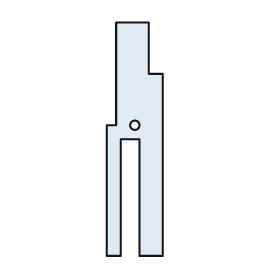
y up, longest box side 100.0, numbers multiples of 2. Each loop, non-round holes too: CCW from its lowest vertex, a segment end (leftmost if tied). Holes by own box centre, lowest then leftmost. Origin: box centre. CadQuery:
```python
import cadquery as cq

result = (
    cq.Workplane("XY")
    .moveTo(-12.0, -50.0)
    .lineTo(-6.0, -50.0)
    .lineTo(-6.0, 0.0)
    .lineTo(2.0, 0.0)
    .lineTo(2.0, -50.0)
    .lineTo(12.0, -50.0)
    .lineTo(12.0, 28.0)
    .lineTo(6.0, 28.0)
    .lineTo(6.0, 50.0)
    .lineTo(-8.0, 50.0)
    .lineTo(-8.0, 6.0)
    .lineTo(-12.0, 6.0)
    .close()
    .moveTo(0.0, 6.0)
    .circle(2.0)
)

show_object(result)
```